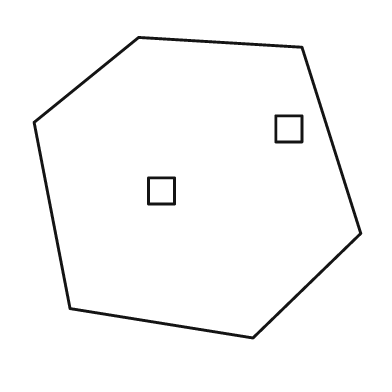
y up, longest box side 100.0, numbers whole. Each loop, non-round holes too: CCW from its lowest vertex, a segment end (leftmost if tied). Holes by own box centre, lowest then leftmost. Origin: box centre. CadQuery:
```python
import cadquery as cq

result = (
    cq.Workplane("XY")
    .moveTo(17.0, -46.0)
    .lineTo(50.0, -14.0)
    .lineTo(32.0, 43.0)
    .lineTo(-18.0, 46.0)
    .lineTo(-50.0, 20.0)
    .lineTo(-39.0, -37.0)
    .close()
    .moveTo(-15.0, -5.0)
    .lineTo(-7.0, -5.0)
    .lineTo(-7.0, 3.0)
    .lineTo(-15.0, 3.0)
    .close()
    .moveTo(24.0, 14.0)
    .lineTo(32.0, 14.0)
    .lineTo(32.0, 22.0)
    .lineTo(24.0, 22.0)
    .close()
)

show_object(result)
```